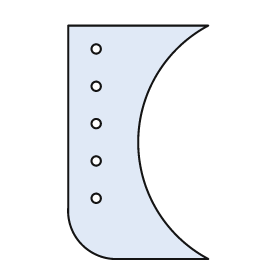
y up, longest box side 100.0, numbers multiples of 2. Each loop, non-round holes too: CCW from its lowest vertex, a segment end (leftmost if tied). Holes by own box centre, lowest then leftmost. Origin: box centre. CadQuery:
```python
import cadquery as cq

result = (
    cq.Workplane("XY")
    .moveTo(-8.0, -50.0)
    .lineTo(30.0, -50.0)
    .threePointArc((0.0, 0.0), (30.0, 50.0))
    .lineTo(-30.0, 50.0)
    .lineTo(-30.0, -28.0)
    .threePointArc((-24.0, -44.0), (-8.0, -50.0))
    .close()
    .moveTo(-18.0, -24.0)
    .circle(2.0)
    .moveTo(-18.0, -8.0)
    .circle(2.0)
    .moveTo(-18.0, 8.0)
    .circle(2.0)
    .moveTo(-18.0, 24.0)
    .circle(2.0)
    .moveTo(-18.0, 40.0)
    .circle(2.0)
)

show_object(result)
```